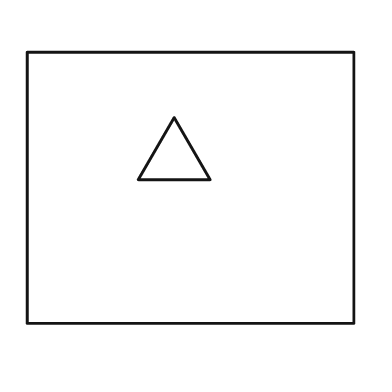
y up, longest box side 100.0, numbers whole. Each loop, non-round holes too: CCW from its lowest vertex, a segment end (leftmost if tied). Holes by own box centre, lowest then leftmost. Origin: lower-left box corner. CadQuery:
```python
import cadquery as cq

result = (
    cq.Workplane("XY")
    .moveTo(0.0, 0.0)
    .lineTo(100.0, 0.0)
    .lineTo(100.0, 83.0)
    .lineTo(0.0, 83.0)
    .close()
    .moveTo(34.0, 44.0)
    .lineTo(56.0, 44.0)
    .lineTo(45.0, 63.0)
    .close()
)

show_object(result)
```